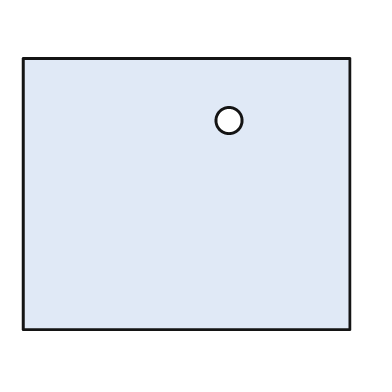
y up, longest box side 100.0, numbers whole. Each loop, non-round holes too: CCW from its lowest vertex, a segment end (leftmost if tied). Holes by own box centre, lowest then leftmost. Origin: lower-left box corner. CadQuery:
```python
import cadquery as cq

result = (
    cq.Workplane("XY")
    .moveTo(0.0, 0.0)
    .lineTo(100.0, 0.0)
    .lineTo(100.0, 83.0)
    .lineTo(0.0, 83.0)
    .close()
    .moveTo(63.0, 64.0)
    .circle(4.0)
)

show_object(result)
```